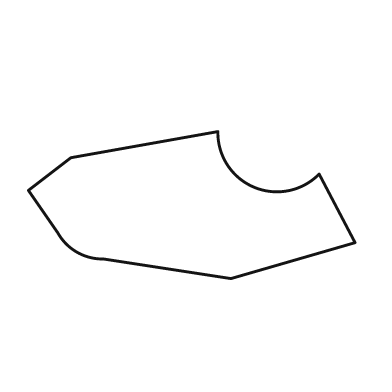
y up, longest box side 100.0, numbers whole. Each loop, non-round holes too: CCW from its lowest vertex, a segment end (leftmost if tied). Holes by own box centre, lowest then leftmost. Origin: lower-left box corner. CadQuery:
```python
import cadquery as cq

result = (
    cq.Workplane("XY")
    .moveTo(62.0, 0.0)
    .lineTo(100.0, 11.0)
    .lineTo(89.0, 32.0)
    .threePointArc((69.0, 28.0), (58.0, 45.0))
    .lineTo(13.0, 37.0)
    .lineTo(0.0, 27.0)
    .lineTo(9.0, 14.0)
    .threePointArc((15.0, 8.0), (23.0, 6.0))
    .close()
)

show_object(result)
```